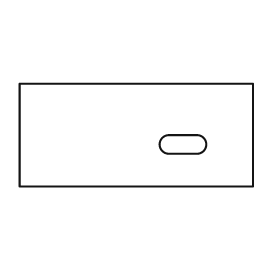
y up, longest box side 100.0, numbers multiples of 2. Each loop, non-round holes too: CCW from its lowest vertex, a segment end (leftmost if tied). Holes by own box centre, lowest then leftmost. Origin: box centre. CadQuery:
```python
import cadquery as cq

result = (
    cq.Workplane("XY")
    .moveTo(-50.0, -22.0)
    .lineTo(50.0, -22.0)
    .lineTo(50.0, 22.0)
    .lineTo(-50.0, 22.0)
    .close()
    .moveTo(14.0, -8.0)
    .lineTo(26.0, -8.0)
    .threePointArc((30.0, -4.0), (26.0, 0.0))
    .lineTo(14.0, 0.0)
    .threePointArc((10.0, -4.0), (14.0, -8.0))
    .close()
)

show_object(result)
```